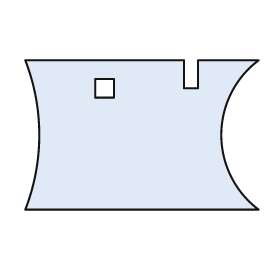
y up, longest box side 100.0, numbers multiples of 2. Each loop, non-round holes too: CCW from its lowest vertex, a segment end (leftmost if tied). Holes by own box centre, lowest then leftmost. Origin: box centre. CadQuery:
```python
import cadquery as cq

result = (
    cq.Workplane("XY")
    .moveTo(-50.0, -32.0)
    .lineTo(50.0, -32.0)
    .threePointArc((34.0, 0.0), (50.0, 32.0))
    .lineTo(24.0, 32.0)
    .lineTo(24.0, 20.0)
    .lineTo(18.0, 20.0)
    .lineTo(18.0, 32.0)
    .lineTo(-50.0, 32.0)
    .threePointArc((-44.0, 0.0), (-50.0, -32.0))
    .close()
    .moveTo(-20.0, 16.0)
    .lineTo(-12.0, 16.0)
    .lineTo(-12.0, 24.0)
    .lineTo(-20.0, 24.0)
    .close()
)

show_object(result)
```